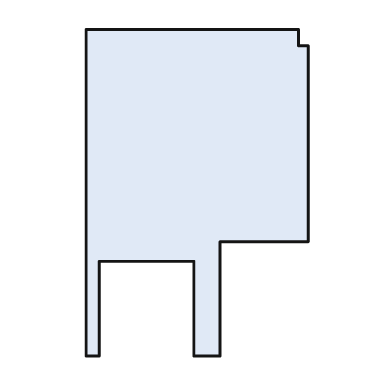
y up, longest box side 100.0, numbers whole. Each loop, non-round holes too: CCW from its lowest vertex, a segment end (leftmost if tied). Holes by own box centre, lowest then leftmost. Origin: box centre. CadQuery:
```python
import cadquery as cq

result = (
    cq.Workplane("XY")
    .moveTo(-34.0, -50.0)
    .lineTo(-30.0, -50.0)
    .lineTo(-30.0, -21.0)
    .lineTo(-1.0, -21.0)
    .lineTo(-1.0, -50.0)
    .lineTo(7.0, -50.0)
    .lineTo(7.0, -15.0)
    .lineTo(34.0, -15.0)
    .lineTo(34.0, 45.0)
    .lineTo(31.0, 45.0)
    .lineTo(31.0, 50.0)
    .lineTo(-34.0, 50.0)
    .close()
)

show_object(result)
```